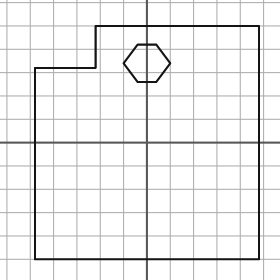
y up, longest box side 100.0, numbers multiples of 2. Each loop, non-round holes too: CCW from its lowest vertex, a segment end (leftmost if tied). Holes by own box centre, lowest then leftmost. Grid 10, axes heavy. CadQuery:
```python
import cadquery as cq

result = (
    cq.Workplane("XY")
    .moveTo(-48.0, -50.0)
    .lineTo(48.0, -50.0)
    .lineTo(48.0, 50.0)
    .lineTo(-22.0, 50.0)
    .lineTo(-22.0, 32.0)
    .lineTo(-48.0, 32.0)
    .close()
    .moveTo(-4.0, 26.0)
    .lineTo(4.0, 26.0)
    .lineTo(10.0, 34.0)
    .lineTo(4.0, 42.0)
    .lineTo(-4.0, 42.0)
    .lineTo(-10.0, 34.0)
    .close()
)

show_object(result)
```